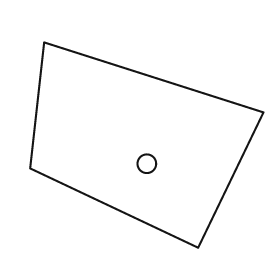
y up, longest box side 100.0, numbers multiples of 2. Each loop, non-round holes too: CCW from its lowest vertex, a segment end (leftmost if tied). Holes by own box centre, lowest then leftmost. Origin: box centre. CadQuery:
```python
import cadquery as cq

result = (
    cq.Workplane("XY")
    .moveTo(22.0, -44.0)
    .lineTo(50.0, 14.0)
    .lineTo(-44.0, 44.0)
    .lineTo(-50.0, -10.0)
    .close()
    .moveTo(0.0, -8.0)
    .circle(4.0)
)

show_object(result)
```